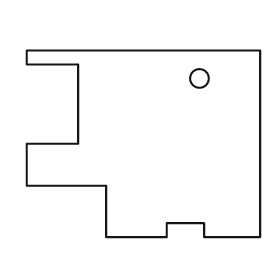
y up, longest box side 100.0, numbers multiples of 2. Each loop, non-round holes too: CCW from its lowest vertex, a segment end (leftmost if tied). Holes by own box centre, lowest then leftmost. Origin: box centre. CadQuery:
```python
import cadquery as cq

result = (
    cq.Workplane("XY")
    .moveTo(-16.0, -40.0)
    .lineTo(10.0, -40.0)
    .lineTo(10.0, -34.0)
    .lineTo(26.0, -34.0)
    .lineTo(26.0, -40.0)
    .lineTo(50.0, -40.0)
    .lineTo(50.0, 40.0)
    .lineTo(-50.0, 40.0)
    .lineTo(-50.0, 34.0)
    .lineTo(-28.0, 34.0)
    .lineTo(-28.0, 0.0)
    .lineTo(-50.0, 0.0)
    .lineTo(-50.0, -18.0)
    .lineTo(-16.0, -18.0)
    .close()
    .moveTo(24.0, 28.0)
    .circle(4.0)
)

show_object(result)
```